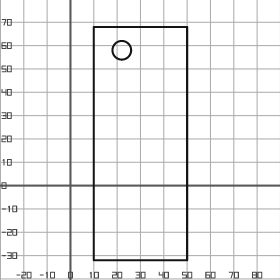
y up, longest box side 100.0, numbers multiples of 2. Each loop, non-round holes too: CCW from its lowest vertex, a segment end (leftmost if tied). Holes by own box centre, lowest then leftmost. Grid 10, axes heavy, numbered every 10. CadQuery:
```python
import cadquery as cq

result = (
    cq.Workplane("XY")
    .moveTo(10.0, -32.0)
    .lineTo(50.0, -32.0)
    .lineTo(50.0, 68.0)
    .lineTo(10.0, 68.0)
    .close()
    .moveTo(22.0, 58.0)
    .circle(4.0)
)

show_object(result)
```